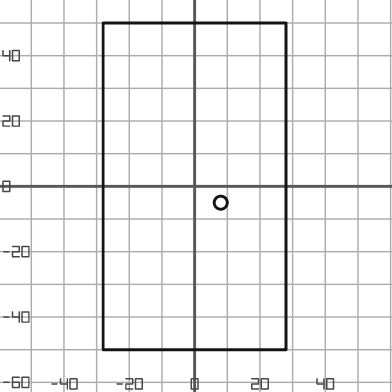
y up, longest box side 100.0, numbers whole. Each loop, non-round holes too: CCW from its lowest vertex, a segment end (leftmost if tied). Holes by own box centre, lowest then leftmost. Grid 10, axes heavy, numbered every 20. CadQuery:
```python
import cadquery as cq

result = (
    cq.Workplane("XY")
    .moveTo(-28.0, -50.0)
    .lineTo(28.0, -50.0)
    .lineTo(28.0, 50.0)
    .lineTo(-28.0, 50.0)
    .close()
    .moveTo(8.0, -5.0)
    .circle(2.0)
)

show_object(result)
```